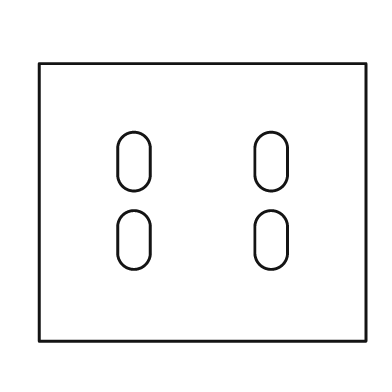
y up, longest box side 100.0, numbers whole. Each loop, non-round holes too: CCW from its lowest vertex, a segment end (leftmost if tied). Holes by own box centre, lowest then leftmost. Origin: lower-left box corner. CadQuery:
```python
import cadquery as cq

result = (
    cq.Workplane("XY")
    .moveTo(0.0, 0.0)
    .lineTo(100.0, 0.0)
    .lineTo(100.0, 85.0)
    .lineTo(0.0, 85.0)
    .close()
    .moveTo(24.0, 27.0)
    .threePointArc((29.0, 22.0), (34.0, 27.0))
    .lineTo(34.0, 35.0)
    .threePointArc((29.0, 40.0), (24.0, 35.0))
    .close()
    .moveTo(66.0, 27.0)
    .threePointArc((71.0, 22.0), (76.0, 27.0))
    .lineTo(76.0, 35.0)
    .threePointArc((71.0, 40.0), (66.0, 35.0))
    .close()
    .moveTo(24.0, 51.0)
    .threePointArc((29.0, 46.0), (34.0, 51.0))
    .lineTo(34.0, 59.0)
    .threePointArc((29.0, 64.0), (24.0, 59.0))
    .close()
    .moveTo(66.0, 51.0)
    .threePointArc((71.0, 46.0), (76.0, 51.0))
    .lineTo(76.0, 59.0)
    .threePointArc((71.0, 64.0), (66.0, 59.0))
    .close()
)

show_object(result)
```